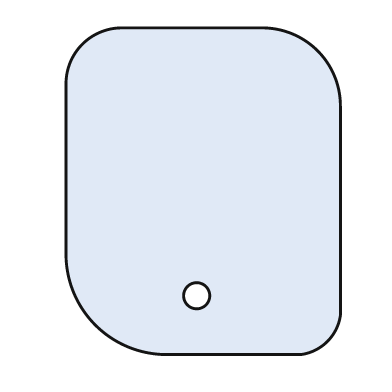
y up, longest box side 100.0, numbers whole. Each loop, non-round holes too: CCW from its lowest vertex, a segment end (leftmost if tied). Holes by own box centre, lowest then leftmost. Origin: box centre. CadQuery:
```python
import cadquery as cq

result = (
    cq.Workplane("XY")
    .moveTo(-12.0, -50.0)
    .lineTo(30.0, -50.0)
    .threePointArc((38.0, -46.0), (42.0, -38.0))
    .lineTo(42.0, 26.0)
    .threePointArc((35.0, 43.0), (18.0, 50.0))
    .lineTo(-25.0, 50.0)
    .threePointArc((-37.0, 45.0), (-42.0, 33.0))
    .lineTo(-42.0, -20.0)
    .threePointArc((-33.0, -41.0), (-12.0, -50.0))
    .close()
    .moveTo(-2.0, -32.0)
    .circle(4.0)
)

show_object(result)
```